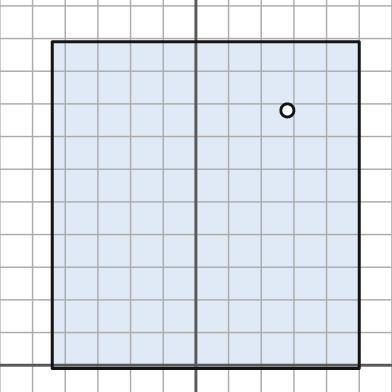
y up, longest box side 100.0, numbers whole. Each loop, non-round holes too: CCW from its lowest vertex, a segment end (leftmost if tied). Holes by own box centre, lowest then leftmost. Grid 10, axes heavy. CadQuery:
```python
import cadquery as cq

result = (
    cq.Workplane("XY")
    .moveTo(-44.0, -1.0)
    .lineTo(50.0, -1.0)
    .lineTo(50.0, 99.0)
    .lineTo(-44.0, 99.0)
    .close()
    .moveTo(28.0, 78.0)
    .circle(2.0)
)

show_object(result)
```